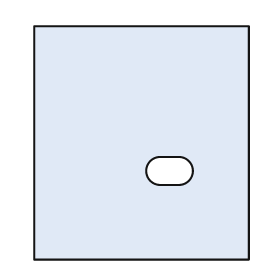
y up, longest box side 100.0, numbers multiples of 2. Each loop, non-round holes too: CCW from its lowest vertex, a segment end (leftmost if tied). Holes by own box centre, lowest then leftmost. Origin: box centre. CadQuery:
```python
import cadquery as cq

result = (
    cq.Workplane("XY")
    .moveTo(-46.0, -50.0)
    .lineTo(46.0, -50.0)
    .lineTo(46.0, 50.0)
    .lineTo(-46.0, 50.0)
    .close()
    .moveTo(8.0, -18.0)
    .lineTo(16.0, -18.0)
    .threePointArc((22.0, -12.0), (16.0, -6.0))
    .lineTo(8.0, -6.0)
    .threePointArc((2.0, -12.0), (8.0, -18.0))
    .close()
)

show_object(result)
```